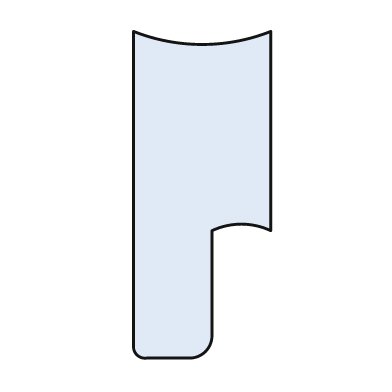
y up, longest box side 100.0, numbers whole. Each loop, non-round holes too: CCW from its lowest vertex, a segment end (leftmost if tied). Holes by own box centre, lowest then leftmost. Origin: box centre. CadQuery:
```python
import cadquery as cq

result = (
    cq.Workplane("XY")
    .moveTo(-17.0, -50.0)
    .lineTo(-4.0, -50.0)
    .threePointArc((1.0, -48.0), (3.0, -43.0))
    .lineTo(3.0, -11.0)
    .threePointArc((12.0, -9.0), (21.0, -11.0))
    .lineTo(21.0, 50.0)
    .threePointArc((0.0, 46.0), (-21.0, 50.0))
    .lineTo(-21.0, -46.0)
    .threePointArc((-20.0, -49.0), (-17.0, -50.0))
    .close()
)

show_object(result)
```